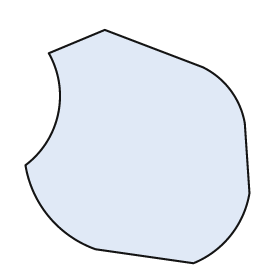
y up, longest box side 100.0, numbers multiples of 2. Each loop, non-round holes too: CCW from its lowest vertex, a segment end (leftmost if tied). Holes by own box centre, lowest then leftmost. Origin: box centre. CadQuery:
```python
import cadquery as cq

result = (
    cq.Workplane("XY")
    .moveTo(24.0, -50.0)
    .threePointArc((40.0, -38.0), (48.0, -20.0))
    .lineTo(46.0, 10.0)
    .threePointArc((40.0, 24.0), (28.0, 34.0))
    .lineTo(-14.0, 50.0)
    .lineTo(-38.0, 40.0)
    .threePointArc((-34.0, 14.0), (-48.0, -8.0))
    .threePointArc((-38.0, -30.0), (-18.0, -44.0))
    .close()
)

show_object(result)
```